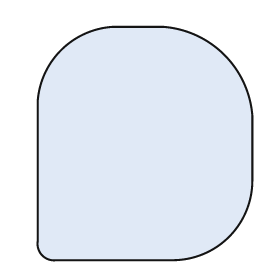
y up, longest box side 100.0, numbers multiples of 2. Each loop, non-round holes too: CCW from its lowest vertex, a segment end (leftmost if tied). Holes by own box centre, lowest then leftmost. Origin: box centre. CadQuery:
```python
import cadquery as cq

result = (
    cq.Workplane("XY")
    .moveTo(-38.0, -50.0)
    .lineTo(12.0, -50.0)
    .threePointArc((36.0, -40.0), (46.0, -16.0))
    .lineTo(46.0, 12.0)
    .threePointArc((34.0, 38.0), (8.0, 50.0))
    .lineTo(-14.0, 50.0)
    .threePointArc((-36.0, 40.0), (-46.0, 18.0))
    .lineTo(-46.0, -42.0)
    .threePointArc((-44.0, -48.0), (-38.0, -50.0))
    .close()
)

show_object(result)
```